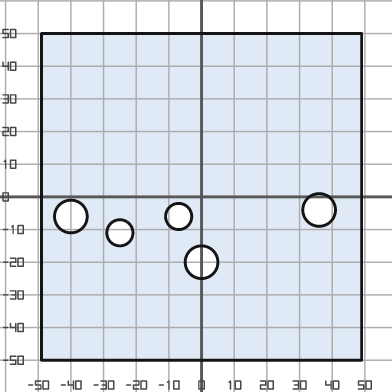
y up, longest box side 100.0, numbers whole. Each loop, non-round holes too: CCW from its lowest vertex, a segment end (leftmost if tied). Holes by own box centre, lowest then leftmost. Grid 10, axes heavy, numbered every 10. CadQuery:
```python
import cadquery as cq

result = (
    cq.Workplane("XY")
    .moveTo(-49.0, -50.0)
    .lineTo(49.0, -50.0)
    .lineTo(49.0, 50.0)
    .lineTo(-49.0, 50.0)
    .close()
    .moveTo(0.0, -20.0)
    .circle(5.0)
    .moveTo(-25.0, -11.0)
    .circle(4.0)
    .moveTo(-40.0, -6.0)
    .circle(5.0)
    .moveTo(-7.0, -6.0)
    .circle(4.0)
    .moveTo(36.0, -4.0)
    .circle(5.0)
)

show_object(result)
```